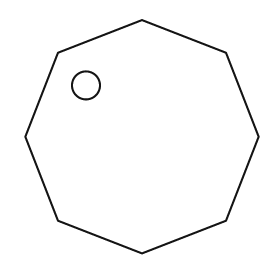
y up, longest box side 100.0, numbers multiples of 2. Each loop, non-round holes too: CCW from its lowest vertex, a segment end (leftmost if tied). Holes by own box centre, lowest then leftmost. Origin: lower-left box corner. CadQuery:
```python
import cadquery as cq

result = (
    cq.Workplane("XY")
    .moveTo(50.0, 0.0)
    .lineTo(86.0, 14.0)
    .lineTo(100.0, 50.0)
    .lineTo(86.0, 86.0)
    .lineTo(50.0, 100.0)
    .lineTo(14.0, 86.0)
    .lineTo(0.0, 50.0)
    .lineTo(14.0, 14.0)
    .close()
    .moveTo(26.0, 72.0)
    .circle(6.0)
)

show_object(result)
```